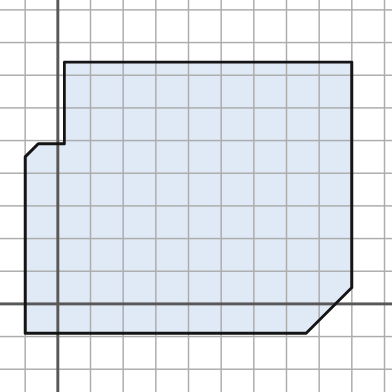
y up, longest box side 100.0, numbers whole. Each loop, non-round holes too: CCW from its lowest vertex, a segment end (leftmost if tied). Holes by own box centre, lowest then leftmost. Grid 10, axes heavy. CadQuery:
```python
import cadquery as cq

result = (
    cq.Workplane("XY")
    .moveTo(-10.0, -9.0)
    .lineTo(76.0, -9.0)
    .lineTo(90.0, 5.0)
    .lineTo(90.0, 74.0)
    .lineTo(2.0, 74.0)
    .lineTo(2.0, 49.0)
    .lineTo(-6.0, 49.0)
    .lineTo(-10.0, 45.0)
    .close()
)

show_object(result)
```